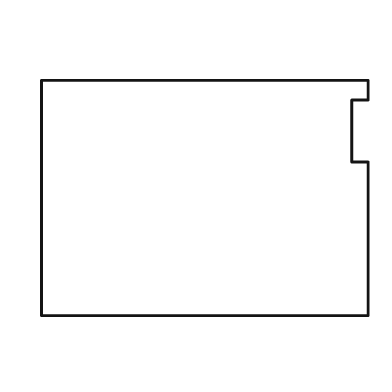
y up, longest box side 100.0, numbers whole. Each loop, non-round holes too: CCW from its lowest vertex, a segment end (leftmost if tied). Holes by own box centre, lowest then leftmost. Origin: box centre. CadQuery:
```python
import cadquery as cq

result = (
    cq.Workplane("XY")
    .moveTo(-50.0, -36.0)
    .lineTo(50.0, -36.0)
    .lineTo(50.0, 11.0)
    .lineTo(45.0, 11.0)
    .lineTo(45.0, 30.0)
    .lineTo(50.0, 30.0)
    .lineTo(50.0, 36.0)
    .lineTo(-50.0, 36.0)
    .close()
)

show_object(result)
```